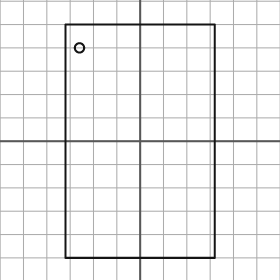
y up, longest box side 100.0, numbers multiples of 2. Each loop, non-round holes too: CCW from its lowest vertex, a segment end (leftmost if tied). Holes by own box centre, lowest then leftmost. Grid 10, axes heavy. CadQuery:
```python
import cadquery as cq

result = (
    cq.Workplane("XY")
    .moveTo(-32.0, -50.0)
    .lineTo(32.0, -50.0)
    .lineTo(32.0, 50.0)
    .lineTo(-32.0, 50.0)
    .close()
    .moveTo(-26.0, 40.0)
    .circle(2.0)
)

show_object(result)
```